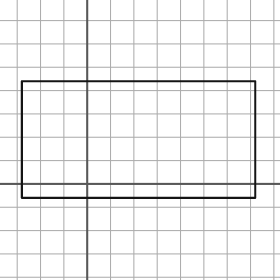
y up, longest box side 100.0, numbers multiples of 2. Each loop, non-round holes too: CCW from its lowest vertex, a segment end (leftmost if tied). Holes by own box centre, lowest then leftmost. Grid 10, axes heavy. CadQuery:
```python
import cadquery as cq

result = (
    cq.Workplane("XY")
    .moveTo(-28.0, -6.0)
    .lineTo(72.0, -6.0)
    .lineTo(72.0, 44.0)
    .lineTo(-28.0, 44.0)
    .close()
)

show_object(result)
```